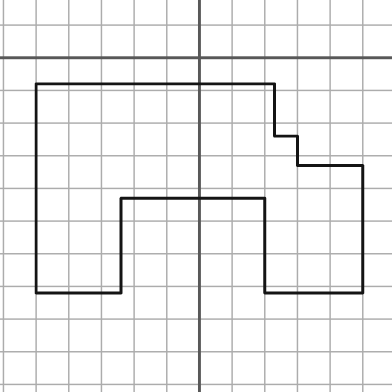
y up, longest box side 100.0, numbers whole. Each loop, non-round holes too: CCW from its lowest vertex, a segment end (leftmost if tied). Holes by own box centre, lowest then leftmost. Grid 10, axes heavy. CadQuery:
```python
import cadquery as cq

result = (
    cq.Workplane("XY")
    .moveTo(-50.0, -72.0)
    .lineTo(-24.0, -72.0)
    .lineTo(-24.0, -43.0)
    .lineTo(20.0, -43.0)
    .lineTo(20.0, -72.0)
    .lineTo(50.0, -72.0)
    .lineTo(50.0, -33.0)
    .lineTo(30.0, -33.0)
    .lineTo(30.0, -24.0)
    .lineTo(23.0, -24.0)
    .lineTo(23.0, -8.0)
    .lineTo(-50.0, -8.0)
    .close()
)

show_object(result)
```